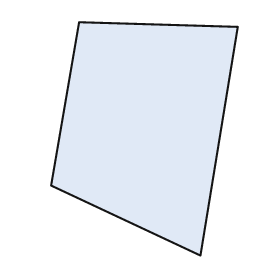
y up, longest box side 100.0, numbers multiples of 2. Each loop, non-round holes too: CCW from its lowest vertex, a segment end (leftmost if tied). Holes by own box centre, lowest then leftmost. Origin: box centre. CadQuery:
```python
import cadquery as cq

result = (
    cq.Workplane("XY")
    .moveTo(24.0, -50.0)
    .lineTo(40.0, 48.0)
    .lineTo(-28.0, 50.0)
    .lineTo(-40.0, -20.0)
    .close()
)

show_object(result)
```